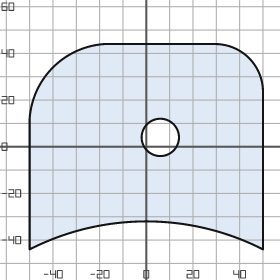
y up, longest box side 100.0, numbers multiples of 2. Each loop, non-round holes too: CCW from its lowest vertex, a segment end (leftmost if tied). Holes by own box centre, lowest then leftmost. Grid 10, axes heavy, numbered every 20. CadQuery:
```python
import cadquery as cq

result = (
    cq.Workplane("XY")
    .moveTo(-50.0, -44.0)
    .threePointArc((0.0, -32.0), (50.0, -44.0))
    .lineTo(50.0, 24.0)
    .threePointArc((44.0, 38.0), (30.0, 44.0))
    .lineTo(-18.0, 44.0)
    .threePointArc((-40.0, 34.0), (-50.0, 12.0))
    .close()
    .moveTo(6.0, 4.0)
    .circle(8.0)
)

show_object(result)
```